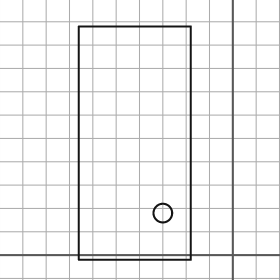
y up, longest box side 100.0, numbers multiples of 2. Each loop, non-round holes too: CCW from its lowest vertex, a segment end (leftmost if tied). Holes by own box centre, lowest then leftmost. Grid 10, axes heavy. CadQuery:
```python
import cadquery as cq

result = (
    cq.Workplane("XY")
    .moveTo(-66.0, -2.0)
    .lineTo(-18.0, -2.0)
    .lineTo(-18.0, 98.0)
    .lineTo(-66.0, 98.0)
    .close()
    .moveTo(-30.0, 18.0)
    .circle(4.0)
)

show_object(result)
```